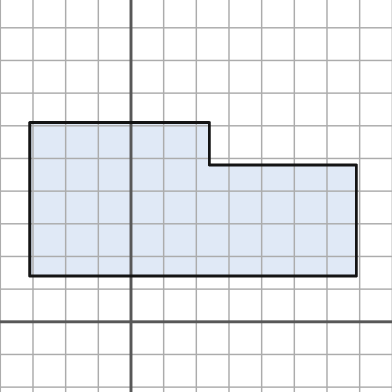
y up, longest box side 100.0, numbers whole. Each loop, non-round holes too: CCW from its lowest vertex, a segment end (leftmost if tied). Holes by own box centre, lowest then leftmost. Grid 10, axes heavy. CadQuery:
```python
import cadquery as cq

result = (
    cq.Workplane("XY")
    .moveTo(-31.0, 14.0)
    .lineTo(69.0, 14.0)
    .lineTo(69.0, 48.0)
    .lineTo(24.0, 48.0)
    .lineTo(24.0, 61.0)
    .lineTo(-31.0, 61.0)
    .close()
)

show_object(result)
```